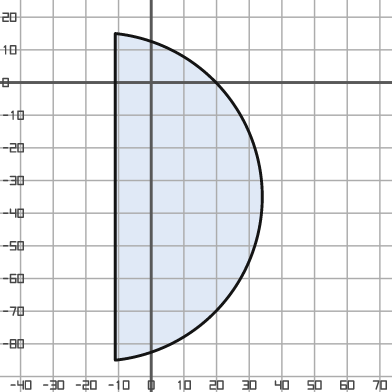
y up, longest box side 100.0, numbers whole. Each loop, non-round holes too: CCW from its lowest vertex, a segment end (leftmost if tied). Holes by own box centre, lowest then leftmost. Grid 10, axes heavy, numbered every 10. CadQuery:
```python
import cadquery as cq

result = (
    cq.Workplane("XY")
    .moveTo(-11.0, -85.0)
    .threePointArc((34.0, -35.0), (-11.0, 15.0))
    .close()
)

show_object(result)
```